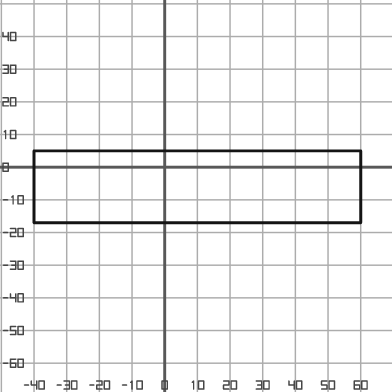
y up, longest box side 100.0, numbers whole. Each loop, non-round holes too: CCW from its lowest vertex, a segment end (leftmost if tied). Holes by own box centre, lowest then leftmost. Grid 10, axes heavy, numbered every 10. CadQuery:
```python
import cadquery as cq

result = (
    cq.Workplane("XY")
    .moveTo(-40.0, -17.0)
    .lineTo(60.0, -17.0)
    .lineTo(60.0, 5.0)
    .lineTo(-40.0, 5.0)
    .close()
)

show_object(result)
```